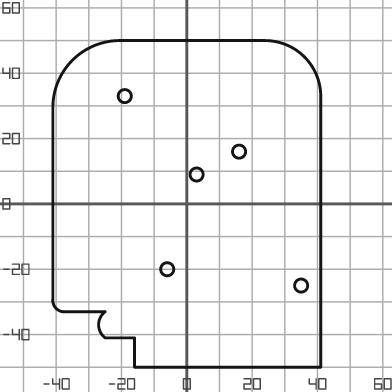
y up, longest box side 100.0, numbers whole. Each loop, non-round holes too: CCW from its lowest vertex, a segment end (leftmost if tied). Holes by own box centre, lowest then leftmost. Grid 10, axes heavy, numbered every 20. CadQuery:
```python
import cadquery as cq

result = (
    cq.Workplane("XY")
    .moveTo(-16.0, -50.0)
    .lineTo(41.0, -50.0)
    .lineTo(41.0, 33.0)
    .threePointArc((36.0, 45.0), (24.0, 50.0))
    .lineTo(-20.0, 50.0)
    .threePointArc((-35.0, 44.0), (-41.0, 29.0))
    .lineTo(-41.0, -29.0)
    .threePointArc((-40.0, -32.0), (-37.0, -33.0))
    .lineTo(-25.0, -33.0)
    .threePointArc((-27.0, -37.0), (-25.0, -41.0))
    .lineTo(-16.0, -41.0)
    .close()
    .moveTo(35.0, -25.0)
    .circle(2.0)
    .moveTo(-6.0, -20.0)
    .circle(2.0)
    .moveTo(3.0, 9.0)
    .circle(2.0)
    .moveTo(16.0, 16.0)
    .circle(2.0)
    .moveTo(-19.0, 33.0)
    .circle(2.0)
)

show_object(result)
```